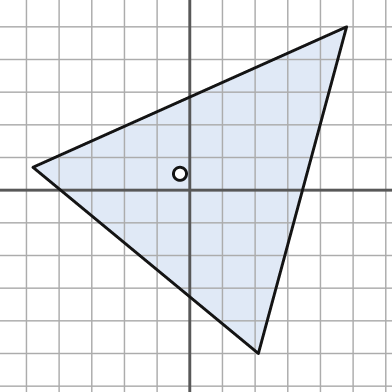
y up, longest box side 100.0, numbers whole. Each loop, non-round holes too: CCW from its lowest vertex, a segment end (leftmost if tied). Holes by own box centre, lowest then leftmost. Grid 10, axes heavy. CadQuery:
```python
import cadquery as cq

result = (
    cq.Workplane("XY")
    .moveTo(21.0, -50.0)
    .lineTo(48.0, 50.0)
    .lineTo(-48.0, 7.0)
    .close()
    .moveTo(-3.0, 5.0)
    .circle(2.0)
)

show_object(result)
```